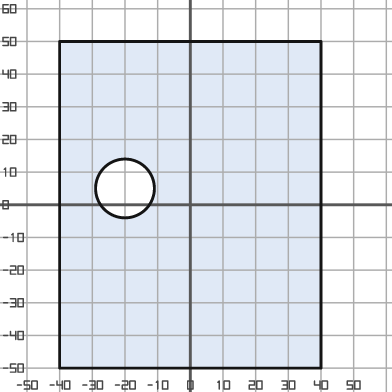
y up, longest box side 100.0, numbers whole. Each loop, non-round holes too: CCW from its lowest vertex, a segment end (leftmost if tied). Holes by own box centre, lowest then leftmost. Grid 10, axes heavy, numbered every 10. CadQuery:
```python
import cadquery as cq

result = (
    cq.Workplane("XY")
    .moveTo(-40.0, -50.0)
    .lineTo(40.0, -50.0)
    .lineTo(40.0, 50.0)
    .lineTo(-40.0, 50.0)
    .close()
    .moveTo(-20.0, 5.0)
    .circle(9.0)
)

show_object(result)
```